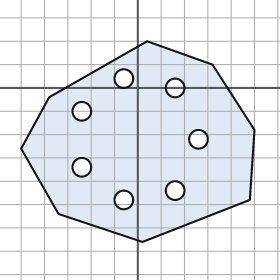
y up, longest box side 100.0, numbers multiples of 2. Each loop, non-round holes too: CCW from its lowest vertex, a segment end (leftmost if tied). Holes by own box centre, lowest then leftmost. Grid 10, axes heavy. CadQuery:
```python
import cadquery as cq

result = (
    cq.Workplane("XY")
    .moveTo(2.0, -66.0)
    .lineTo(48.0, -48.0)
    .lineTo(50.0, -18.0)
    .lineTo(32.0, 10.0)
    .lineTo(4.0, 20.0)
    .lineTo(-38.0, -4.0)
    .lineTo(-50.0, -26.0)
    .lineTo(-34.0, -54.0)
    .close()
    .moveTo(-6.0, -48.0)
    .circle(4.0)
    .moveTo(16.0, -44.0)
    .circle(4.0)
    .moveTo(-24.0, -34.0)
    .circle(4.0)
    .moveTo(26.0, -22.0)
    .circle(4.0)
    .moveTo(-24.0, -10.0)
    .circle(4.0)
    .moveTo(16.0, 0.0)
    .circle(4.0)
    .moveTo(-6.0, 4.0)
    .circle(4.0)
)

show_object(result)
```